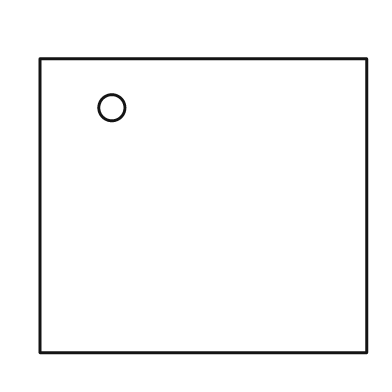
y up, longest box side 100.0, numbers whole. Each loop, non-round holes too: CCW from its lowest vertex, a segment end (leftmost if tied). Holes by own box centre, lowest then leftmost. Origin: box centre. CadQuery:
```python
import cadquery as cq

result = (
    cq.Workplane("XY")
    .moveTo(-50.0, -45.0)
    .lineTo(50.0, -45.0)
    .lineTo(50.0, 45.0)
    .lineTo(-50.0, 45.0)
    .close()
    .moveTo(-28.0, 30.0)
    .circle(4.0)
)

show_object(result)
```